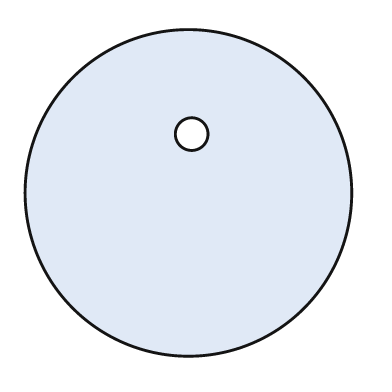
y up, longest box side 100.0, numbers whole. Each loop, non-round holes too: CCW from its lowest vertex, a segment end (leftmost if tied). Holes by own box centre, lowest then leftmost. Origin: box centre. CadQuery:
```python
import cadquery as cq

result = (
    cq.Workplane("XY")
    .moveTo(0.0, 0.0)
    .circle(50.0)
    .moveTo(1.0, 18.0)
    .circle(5.0)
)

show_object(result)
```